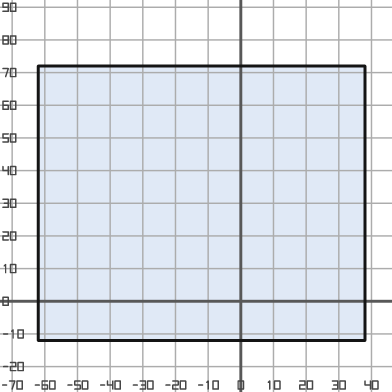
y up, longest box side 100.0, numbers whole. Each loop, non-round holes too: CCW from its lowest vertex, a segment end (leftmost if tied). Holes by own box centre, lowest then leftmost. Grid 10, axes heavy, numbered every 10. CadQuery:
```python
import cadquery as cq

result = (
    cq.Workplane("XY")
    .moveTo(-62.0, -12.0)
    .lineTo(38.0, -12.0)
    .lineTo(38.0, 72.0)
    .lineTo(-62.0, 72.0)
    .close()
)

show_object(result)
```